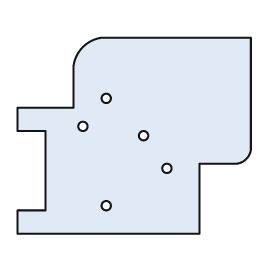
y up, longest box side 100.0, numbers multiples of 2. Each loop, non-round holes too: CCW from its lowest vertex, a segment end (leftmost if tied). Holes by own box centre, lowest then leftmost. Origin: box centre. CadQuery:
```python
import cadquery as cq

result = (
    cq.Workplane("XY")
    .moveTo(-50.0, -42.0)
    .lineTo(28.0, -42.0)
    .lineTo(28.0, -12.0)
    .lineTo(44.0, -12.0)
    .threePointArc((48.0, -10.0), (50.0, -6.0))
    .lineTo(50.0, 42.0)
    .lineTo(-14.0, 42.0)
    .threePointArc((-22.0, 38.0), (-26.0, 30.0))
    .lineTo(-26.0, 12.0)
    .lineTo(-50.0, 12.0)
    .lineTo(-50.0, 2.0)
    .lineTo(-38.0, 2.0)
    .lineTo(-38.0, -32.0)
    .lineTo(-50.0, -32.0)
    .close()
    .moveTo(-12.0, -30.0)
    .circle(2.0)
    .moveTo(14.0, -14.0)
    .circle(2.0)
    .moveTo(4.0, 0.0)
    .circle(2.0)
    .moveTo(-22.0, 4.0)
    .circle(2.0)
    .moveTo(-12.0, 16.0)
    .circle(2.0)
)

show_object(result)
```